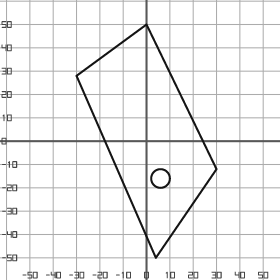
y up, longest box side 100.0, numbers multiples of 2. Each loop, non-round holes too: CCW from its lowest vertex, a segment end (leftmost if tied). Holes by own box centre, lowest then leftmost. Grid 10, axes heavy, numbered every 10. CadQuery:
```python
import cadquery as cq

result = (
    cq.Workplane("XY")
    .moveTo(4.0, -50.0)
    .lineTo(30.0, -12.0)
    .lineTo(0.0, 50.0)
    .lineTo(-30.0, 28.0)
    .close()
    .moveTo(6.0, -16.0)
    .circle(4.0)
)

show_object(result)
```